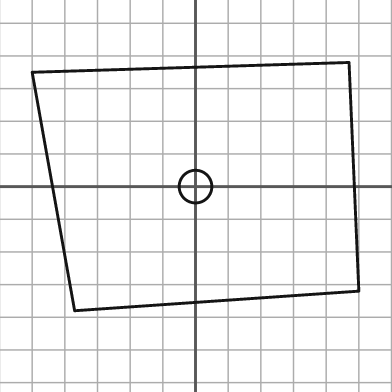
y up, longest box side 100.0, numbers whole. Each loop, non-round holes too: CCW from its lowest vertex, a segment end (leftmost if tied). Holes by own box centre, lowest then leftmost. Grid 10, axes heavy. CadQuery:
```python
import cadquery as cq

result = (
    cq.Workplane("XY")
    .moveTo(-37.0, -38.0)
    .lineTo(50.0, -32.0)
    .lineTo(47.0, 38.0)
    .lineTo(-50.0, 35.0)
    .close()
    .moveTo(0.0, 0.0)
    .circle(5.0)
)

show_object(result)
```